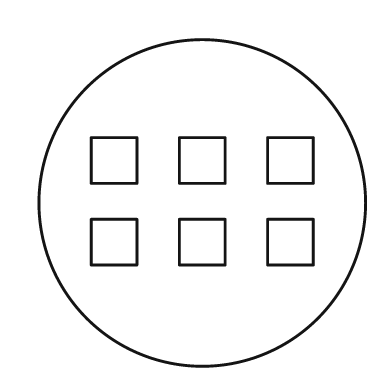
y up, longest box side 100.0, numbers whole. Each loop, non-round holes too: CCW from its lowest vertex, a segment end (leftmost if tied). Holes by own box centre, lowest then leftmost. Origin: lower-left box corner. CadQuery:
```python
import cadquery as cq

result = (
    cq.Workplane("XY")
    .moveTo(50.0, 50.0)
    .circle(50.0)
    .moveTo(16.0, 31.0)
    .lineTo(30.0, 31.0)
    .lineTo(30.0, 45.0)
    .lineTo(16.0, 45.0)
    .close()
    .moveTo(43.0, 31.0)
    .lineTo(57.0, 31.0)
    .lineTo(57.0, 45.0)
    .lineTo(43.0, 45.0)
    .close()
    .moveTo(70.0, 31.0)
    .lineTo(84.0, 31.0)
    .lineTo(84.0, 45.0)
    .lineTo(70.0, 45.0)
    .close()
    .moveTo(16.0, 56.0)
    .lineTo(30.0, 56.0)
    .lineTo(30.0, 70.0)
    .lineTo(16.0, 70.0)
    .close()
    .moveTo(43.0, 56.0)
    .lineTo(57.0, 56.0)
    .lineTo(57.0, 70.0)
    .lineTo(43.0, 70.0)
    .close()
    .moveTo(70.0, 56.0)
    .lineTo(84.0, 56.0)
    .lineTo(84.0, 70.0)
    .lineTo(70.0, 70.0)
    .close()
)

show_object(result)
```